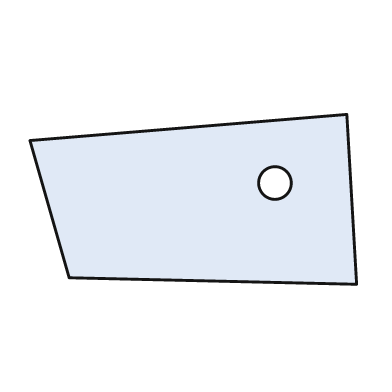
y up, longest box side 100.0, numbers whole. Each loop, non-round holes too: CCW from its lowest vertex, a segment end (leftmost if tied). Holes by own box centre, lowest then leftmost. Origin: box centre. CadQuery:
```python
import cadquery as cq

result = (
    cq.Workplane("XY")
    .moveTo(50.0, -26.0)
    .lineTo(47.0, 26.0)
    .lineTo(-50.0, 18.0)
    .lineTo(-38.0, -24.0)
    .close()
    .moveTo(25.0, 5.0)
    .circle(5.0)
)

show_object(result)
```